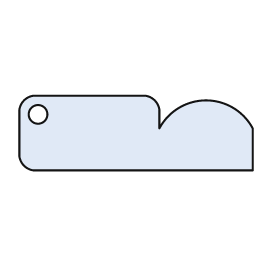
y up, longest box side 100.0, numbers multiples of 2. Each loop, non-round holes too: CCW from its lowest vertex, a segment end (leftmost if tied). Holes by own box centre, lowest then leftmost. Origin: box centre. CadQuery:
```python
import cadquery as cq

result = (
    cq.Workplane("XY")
    .moveTo(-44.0, -16.0)
    .lineTo(50.0, -16.0)
    .lineTo(50.0, 2.0)
    .threePointArc((30.0, 14.0), (10.0, 2.0))
    .lineTo(10.0, 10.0)
    .threePointArc((8.0, 14.0), (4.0, 16.0))
    .lineTo(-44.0, 16.0)
    .threePointArc((-48.0, 14.0), (-50.0, 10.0))
    .lineTo(-50.0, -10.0)
    .threePointArc((-48.0, -14.0), (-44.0, -16.0))
    .close()
    .moveTo(-42.0, 8.0)
    .circle(4.0)
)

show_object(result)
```